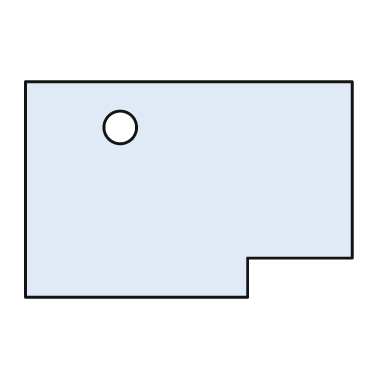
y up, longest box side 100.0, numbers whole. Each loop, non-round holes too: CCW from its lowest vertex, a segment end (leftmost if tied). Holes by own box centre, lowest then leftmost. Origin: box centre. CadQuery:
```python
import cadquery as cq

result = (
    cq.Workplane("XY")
    .moveTo(-50.0, -33.0)
    .lineTo(18.0, -33.0)
    .lineTo(18.0, -21.0)
    .lineTo(50.0, -21.0)
    .lineTo(50.0, 33.0)
    .lineTo(-50.0, 33.0)
    .close()
    .moveTo(-21.0, 19.0)
    .circle(5.0)
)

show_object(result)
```